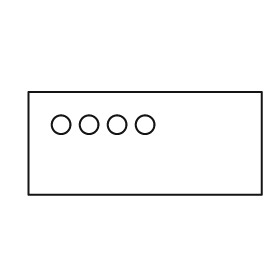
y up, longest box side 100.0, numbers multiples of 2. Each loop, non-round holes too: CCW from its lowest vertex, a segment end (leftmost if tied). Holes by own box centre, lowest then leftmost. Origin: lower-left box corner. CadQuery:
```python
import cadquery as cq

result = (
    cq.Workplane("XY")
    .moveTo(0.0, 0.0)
    .lineTo(100.0, 0.0)
    .lineTo(100.0, 44.0)
    .lineTo(0.0, 44.0)
    .close()
    .moveTo(14.0, 30.0)
    .circle(4.0)
    .moveTo(26.0, 30.0)
    .circle(4.0)
    .moveTo(38.0, 30.0)
    .circle(4.0)
    .moveTo(50.0, 30.0)
    .circle(4.0)
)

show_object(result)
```